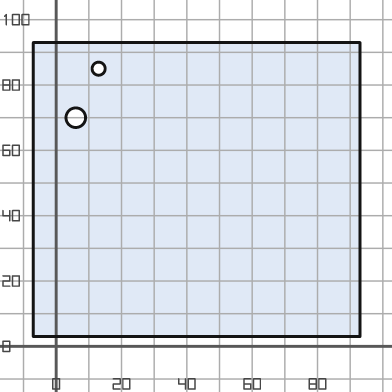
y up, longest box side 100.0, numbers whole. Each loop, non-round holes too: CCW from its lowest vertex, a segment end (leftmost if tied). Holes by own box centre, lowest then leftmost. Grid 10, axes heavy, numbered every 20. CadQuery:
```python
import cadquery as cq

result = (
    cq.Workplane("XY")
    .moveTo(-7.0, 3.0)
    .lineTo(93.0, 3.0)
    .lineTo(93.0, 93.0)
    .lineTo(-7.0, 93.0)
    .close()
    .moveTo(6.0, 70.0)
    .circle(3.0)
    .moveTo(13.0, 85.0)
    .circle(2.0)
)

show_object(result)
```